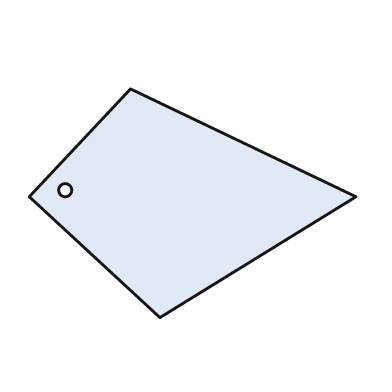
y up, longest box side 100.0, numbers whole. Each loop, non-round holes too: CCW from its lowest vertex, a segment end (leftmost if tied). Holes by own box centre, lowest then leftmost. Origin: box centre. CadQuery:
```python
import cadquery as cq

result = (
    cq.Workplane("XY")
    .moveTo(-10.0, -35.0)
    .lineTo(50.0, 2.0)
    .lineTo(-19.0, 35.0)
    .lineTo(-50.0, 2.0)
    .close()
    .moveTo(-39.0, 4.0)
    .circle(2.0)
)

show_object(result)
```